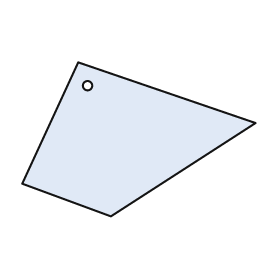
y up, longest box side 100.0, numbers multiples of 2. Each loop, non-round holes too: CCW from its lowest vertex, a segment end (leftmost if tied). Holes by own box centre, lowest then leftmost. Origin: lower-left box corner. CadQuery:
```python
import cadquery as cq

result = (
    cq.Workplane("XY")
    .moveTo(38.0, 0.0)
    .lineTo(100.0, 40.0)
    .lineTo(24.0, 66.0)
    .lineTo(0.0, 14.0)
    .close()
    .moveTo(28.0, 56.0)
    .circle(2.0)
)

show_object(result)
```